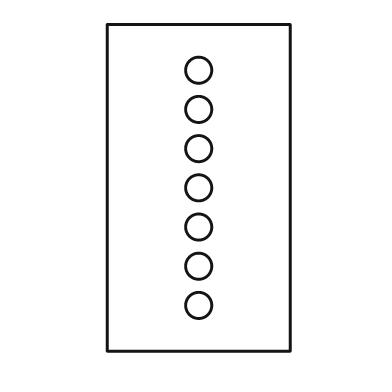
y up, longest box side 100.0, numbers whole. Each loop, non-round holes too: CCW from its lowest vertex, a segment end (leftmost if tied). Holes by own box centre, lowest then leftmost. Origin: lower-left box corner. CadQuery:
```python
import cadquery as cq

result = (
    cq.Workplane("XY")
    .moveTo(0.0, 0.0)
    .lineTo(56.0, 0.0)
    .lineTo(56.0, 100.0)
    .lineTo(0.0, 100.0)
    .close()
    .moveTo(28.0, 14.0)
    .circle(4.0)
    .moveTo(28.0, 26.0)
    .circle(4.0)
    .moveTo(28.0, 38.0)
    .circle(4.0)
    .moveTo(28.0, 50.0)
    .circle(4.0)
    .moveTo(28.0, 62.0)
    .circle(4.0)
    .moveTo(28.0, 74.0)
    .circle(4.0)
    .moveTo(28.0, 86.0)
    .circle(4.0)
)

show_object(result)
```